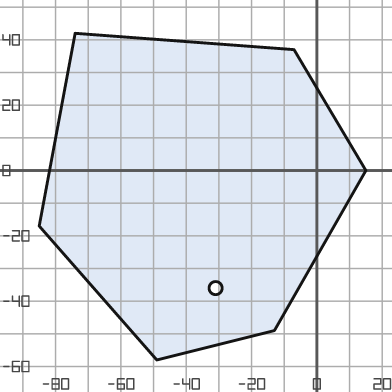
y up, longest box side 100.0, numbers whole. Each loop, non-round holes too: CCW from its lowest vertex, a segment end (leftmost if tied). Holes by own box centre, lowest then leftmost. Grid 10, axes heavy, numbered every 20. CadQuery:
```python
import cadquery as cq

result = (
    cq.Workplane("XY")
    .moveTo(-49.0, -58.0)
    .lineTo(-13.0, -49.0)
    .lineTo(15.0, 0.0)
    .lineTo(-7.0, 37.0)
    .lineTo(-74.0, 42.0)
    .lineTo(-85.0, -17.0)
    .close()
    .moveTo(-31.0, -36.0)
    .circle(2.0)
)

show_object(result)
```